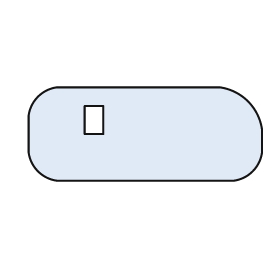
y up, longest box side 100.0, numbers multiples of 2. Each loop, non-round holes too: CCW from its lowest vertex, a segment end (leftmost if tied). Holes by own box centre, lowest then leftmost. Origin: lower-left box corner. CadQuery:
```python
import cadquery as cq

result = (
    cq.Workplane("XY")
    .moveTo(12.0, 0.0)
    .lineTo(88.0, 0.0)
    .threePointArc((96.0, 4.0), (100.0, 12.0))
    .lineTo(100.0, 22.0)
    .threePointArc((94.0, 34.0), (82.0, 40.0))
    .lineTo(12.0, 40.0)
    .threePointArc((4.0, 36.0), (0.0, 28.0))
    .lineTo(0.0, 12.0)
    .threePointArc((4.0, 4.0), (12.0, 0.0))
    .close()
    .moveTo(24.0, 20.0)
    .lineTo(32.0, 20.0)
    .lineTo(32.0, 32.0)
    .lineTo(24.0, 32.0)
    .close()
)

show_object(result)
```